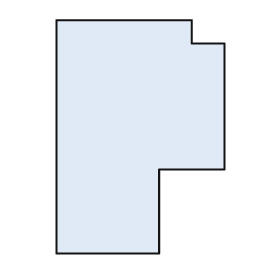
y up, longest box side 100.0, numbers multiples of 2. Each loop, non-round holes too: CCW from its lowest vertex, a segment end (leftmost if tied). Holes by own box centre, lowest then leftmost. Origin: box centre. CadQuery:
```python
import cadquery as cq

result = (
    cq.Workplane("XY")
    .moveTo(-36.0, -50.0)
    .lineTo(8.0, -50.0)
    .lineTo(8.0, -14.0)
    .lineTo(36.0, -14.0)
    .lineTo(36.0, 40.0)
    .lineTo(22.0, 40.0)
    .lineTo(22.0, 50.0)
    .lineTo(-36.0, 50.0)
    .close()
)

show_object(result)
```